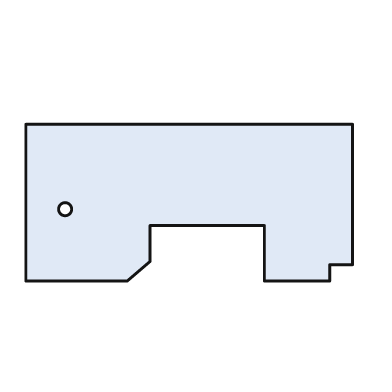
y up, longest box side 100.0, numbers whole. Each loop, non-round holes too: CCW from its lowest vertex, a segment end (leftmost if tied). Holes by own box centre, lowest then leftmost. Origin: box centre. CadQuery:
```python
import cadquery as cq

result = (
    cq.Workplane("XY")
    .moveTo(-50.0, -24.0)
    .lineTo(-19.0, -24.0)
    .lineTo(-12.0, -18.0)
    .lineTo(-12.0, -7.0)
    .lineTo(23.0, -7.0)
    .lineTo(23.0, -24.0)
    .lineTo(43.0, -24.0)
    .lineTo(43.0, -19.0)
    .lineTo(50.0, -19.0)
    .lineTo(50.0, 24.0)
    .lineTo(-50.0, 24.0)
    .close()
    .moveTo(-38.0, -2.0)
    .circle(2.0)
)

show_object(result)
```